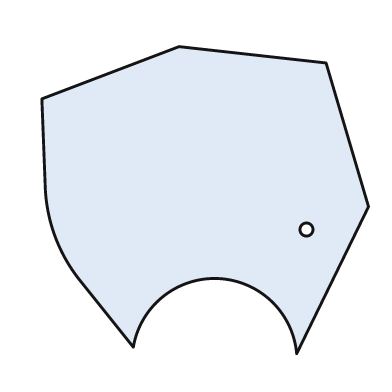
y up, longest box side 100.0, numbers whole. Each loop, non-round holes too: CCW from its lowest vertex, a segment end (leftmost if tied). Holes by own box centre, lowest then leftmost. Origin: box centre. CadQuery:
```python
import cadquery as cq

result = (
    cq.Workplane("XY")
    .moveTo(28.0, -47.0)
    .lineTo(50.0, -2.0)
    .lineTo(37.0, 42.0)
    .lineTo(-8.0, 47.0)
    .lineTo(-50.0, 31.0)
    .lineTo(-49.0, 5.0)
    .threePointArc((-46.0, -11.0), (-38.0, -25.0))
    .lineTo(-22.0, -45.0)
    .threePointArc((4.0, -24.0), (28.0, -47.0))
    .close()
    .moveTo(31.0, -9.0)
    .circle(2.0)
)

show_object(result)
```